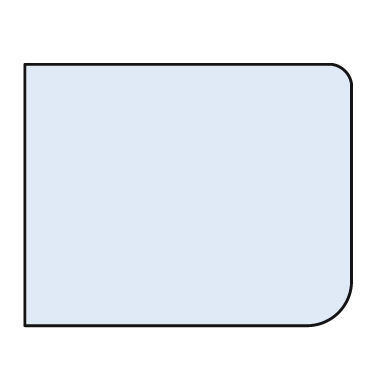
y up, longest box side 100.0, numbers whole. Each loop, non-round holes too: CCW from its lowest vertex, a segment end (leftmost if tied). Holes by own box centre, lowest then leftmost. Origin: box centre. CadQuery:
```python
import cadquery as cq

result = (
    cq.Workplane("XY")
    .moveTo(-50.0, -40.0)
    .lineTo(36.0, -40.0)
    .threePointArc((46.0, -36.0), (50.0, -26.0))
    .lineTo(50.0, 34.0)
    .threePointArc((48.0, 38.0), (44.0, 40.0))
    .lineTo(-50.0, 40.0)
    .close()
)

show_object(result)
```